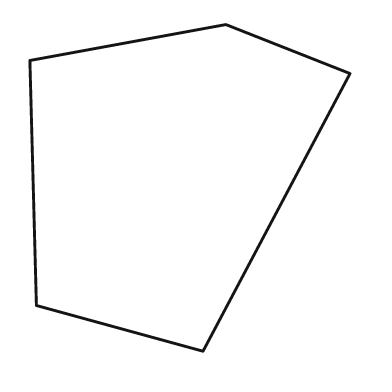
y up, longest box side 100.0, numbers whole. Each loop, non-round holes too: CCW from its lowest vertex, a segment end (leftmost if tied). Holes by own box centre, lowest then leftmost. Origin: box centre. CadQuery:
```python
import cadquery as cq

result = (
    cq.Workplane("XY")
    .moveTo(4.0, -50.0)
    .lineTo(49.0, 35.0)
    .lineTo(11.0, 50.0)
    .lineTo(-49.0, 39.0)
    .lineTo(-47.0, -36.0)
    .close()
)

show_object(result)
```